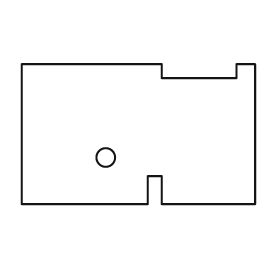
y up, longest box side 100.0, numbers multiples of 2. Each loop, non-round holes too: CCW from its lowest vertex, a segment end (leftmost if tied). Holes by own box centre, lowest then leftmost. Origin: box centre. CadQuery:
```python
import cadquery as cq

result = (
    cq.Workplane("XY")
    .moveTo(-50.0, -30.0)
    .lineTo(4.0, -30.0)
    .lineTo(4.0, -18.0)
    .lineTo(10.0, -18.0)
    .lineTo(10.0, -30.0)
    .lineTo(50.0, -30.0)
    .lineTo(50.0, 30.0)
    .lineTo(42.0, 30.0)
    .lineTo(42.0, 24.0)
    .lineTo(10.0, 24.0)
    .lineTo(10.0, 30.0)
    .lineTo(-50.0, 30.0)
    .close()
    .moveTo(-14.0, -10.0)
    .circle(4.0)
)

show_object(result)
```